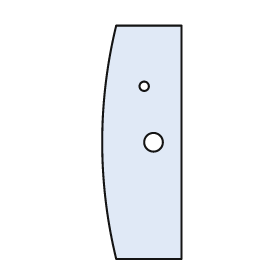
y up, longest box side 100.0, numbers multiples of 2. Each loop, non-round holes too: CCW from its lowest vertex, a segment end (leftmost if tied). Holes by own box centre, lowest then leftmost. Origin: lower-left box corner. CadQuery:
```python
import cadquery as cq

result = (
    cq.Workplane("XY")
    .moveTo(6.0, 0.0)
    .lineTo(34.0, 0.0)
    .lineTo(34.0, 100.0)
    .lineTo(6.0, 100.0)
    .threePointArc((0.0, 50.0), (6.0, 0.0))
    .close()
    .moveTo(22.0, 50.0)
    .circle(4.0)
    .moveTo(18.0, 74.0)
    .circle(2.0)
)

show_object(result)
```